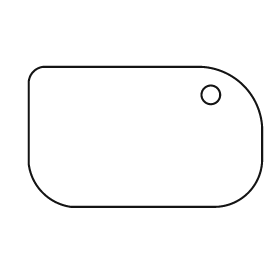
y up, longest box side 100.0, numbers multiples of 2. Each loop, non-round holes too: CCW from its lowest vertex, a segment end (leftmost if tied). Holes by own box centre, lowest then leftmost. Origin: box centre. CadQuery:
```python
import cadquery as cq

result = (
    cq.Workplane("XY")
    .moveTo(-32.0, -30.0)
    .lineTo(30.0, -30.0)
    .threePointArc((44.0, -24.0), (50.0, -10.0))
    .lineTo(50.0, 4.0)
    .threePointArc((42.0, 22.0), (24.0, 30.0))
    .lineTo(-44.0, 30.0)
    .threePointArc((-48.0, 28.0), (-50.0, 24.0))
    .lineTo(-50.0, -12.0)
    .threePointArc((-44.0, -24.0), (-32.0, -30.0))
    .close()
    .moveTo(28.0, 18.0)
    .circle(4.0)
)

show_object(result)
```